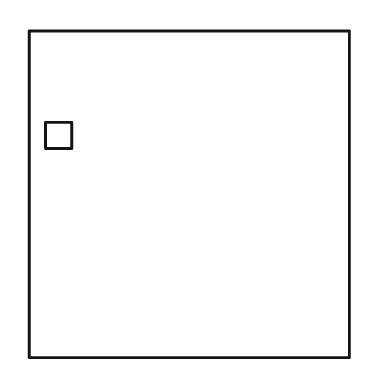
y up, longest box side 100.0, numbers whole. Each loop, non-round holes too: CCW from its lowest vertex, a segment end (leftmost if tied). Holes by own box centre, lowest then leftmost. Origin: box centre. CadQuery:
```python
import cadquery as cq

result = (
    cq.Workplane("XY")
    .moveTo(-49.0, -50.0)
    .lineTo(49.0, -50.0)
    .lineTo(49.0, 50.0)
    .lineTo(-49.0, 50.0)
    .close()
    .moveTo(-44.0, 14.0)
    .lineTo(-36.0, 14.0)
    .lineTo(-36.0, 22.0)
    .lineTo(-44.0, 22.0)
    .close()
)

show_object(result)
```